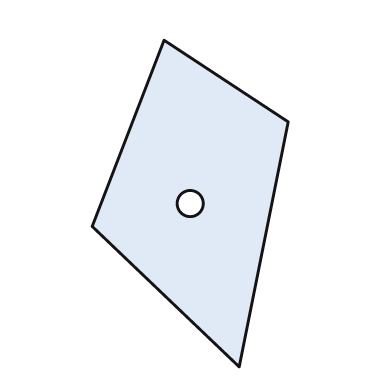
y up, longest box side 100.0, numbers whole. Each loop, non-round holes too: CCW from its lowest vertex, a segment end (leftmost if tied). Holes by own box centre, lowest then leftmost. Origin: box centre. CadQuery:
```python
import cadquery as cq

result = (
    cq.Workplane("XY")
    .moveTo(15.0, -50.0)
    .lineTo(30.0, 25.0)
    .lineTo(-8.0, 50.0)
    .lineTo(-30.0, -7.0)
    .close()
    .moveTo(0.0, 0.0)
    .circle(4.0)
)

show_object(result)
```